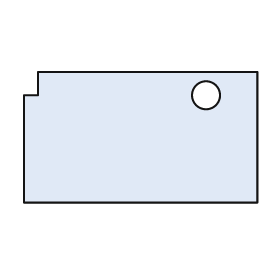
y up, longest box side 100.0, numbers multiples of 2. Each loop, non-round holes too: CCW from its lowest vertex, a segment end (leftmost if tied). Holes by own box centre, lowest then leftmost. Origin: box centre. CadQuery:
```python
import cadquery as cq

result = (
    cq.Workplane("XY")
    .moveTo(-50.0, -28.0)
    .lineTo(50.0, -28.0)
    .lineTo(50.0, 28.0)
    .lineTo(-44.0, 28.0)
    .lineTo(-44.0, 18.0)
    .lineTo(-50.0, 18.0)
    .close()
    .moveTo(28.0, 18.0)
    .circle(6.0)
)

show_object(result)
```